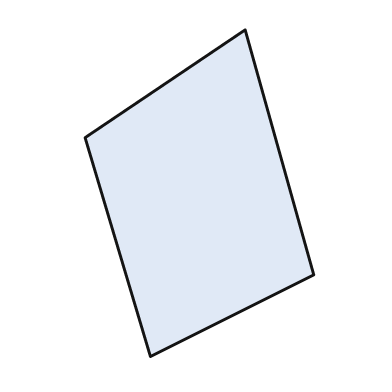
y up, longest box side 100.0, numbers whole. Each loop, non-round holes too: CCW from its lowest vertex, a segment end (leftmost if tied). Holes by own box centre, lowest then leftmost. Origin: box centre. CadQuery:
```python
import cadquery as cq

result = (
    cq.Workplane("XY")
    .moveTo(-15.0, -50.0)
    .lineTo(35.0, -25.0)
    .lineTo(14.0, 50.0)
    .lineTo(-35.0, 17.0)
    .close()
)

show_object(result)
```